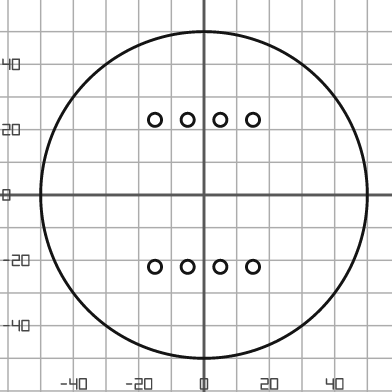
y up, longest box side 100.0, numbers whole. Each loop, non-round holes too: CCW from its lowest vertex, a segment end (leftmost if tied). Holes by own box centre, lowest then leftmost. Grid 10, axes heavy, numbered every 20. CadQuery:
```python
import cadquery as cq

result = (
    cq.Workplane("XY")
    .moveTo(0.0, 0.0)
    .circle(50.0)
    .moveTo(-15.0, -22.0)
    .circle(2.0)
    .moveTo(-5.0, -22.0)
    .circle(2.0)
    .moveTo(5.0, -22.0)
    .circle(2.0)
    .moveTo(15.0, -22.0)
    .circle(2.0)
    .moveTo(-15.0, 23.0)
    .circle(2.0)
    .moveTo(-5.0, 23.0)
    .circle(2.0)
    .moveTo(5.0, 23.0)
    .circle(2.0)
    .moveTo(15.0, 23.0)
    .circle(2.0)
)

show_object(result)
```